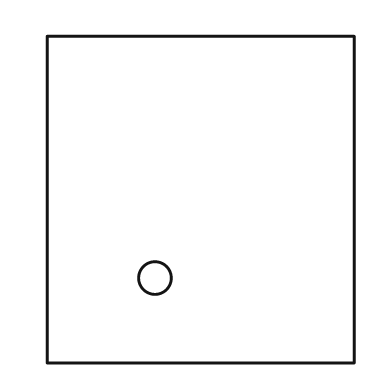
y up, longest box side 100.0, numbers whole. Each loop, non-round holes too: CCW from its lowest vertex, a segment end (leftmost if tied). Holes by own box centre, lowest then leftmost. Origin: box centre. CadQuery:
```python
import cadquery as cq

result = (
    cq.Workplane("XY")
    .moveTo(-47.0, -50.0)
    .lineTo(47.0, -50.0)
    .lineTo(47.0, 50.0)
    .lineTo(-47.0, 50.0)
    .close()
    .moveTo(-14.0, -24.0)
    .circle(5.0)
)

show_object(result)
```